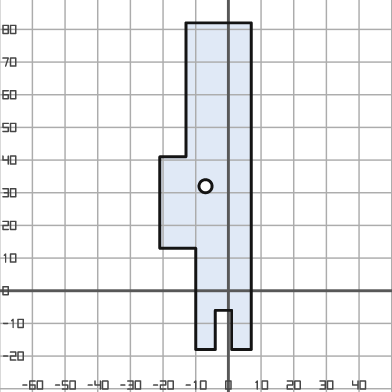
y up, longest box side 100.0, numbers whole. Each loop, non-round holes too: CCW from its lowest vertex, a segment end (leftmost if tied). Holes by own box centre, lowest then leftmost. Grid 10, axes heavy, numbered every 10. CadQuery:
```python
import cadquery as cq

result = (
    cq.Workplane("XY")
    .moveTo(-10.0, -18.0)
    .lineTo(-4.0, -18.0)
    .lineTo(-4.0, -6.0)
    .lineTo(1.0, -6.0)
    .lineTo(1.0, -18.0)
    .lineTo(7.0, -18.0)
    .lineTo(7.0, 82.0)
    .lineTo(-13.0, 82.0)
    .lineTo(-13.0, 41.0)
    .lineTo(-21.0, 41.0)
    .lineTo(-21.0, 13.0)
    .lineTo(-10.0, 13.0)
    .close()
    .moveTo(-7.0, 32.0)
    .circle(2.0)
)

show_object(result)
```